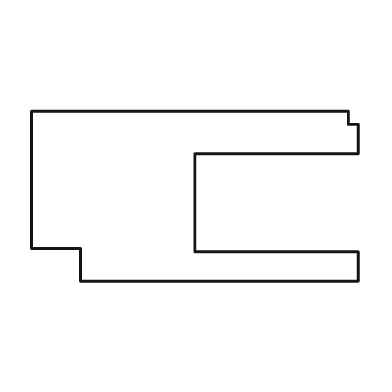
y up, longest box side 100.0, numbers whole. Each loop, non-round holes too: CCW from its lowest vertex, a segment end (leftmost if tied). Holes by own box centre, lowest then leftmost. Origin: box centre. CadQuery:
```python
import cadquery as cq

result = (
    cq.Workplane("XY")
    .moveTo(-35.0, -26.0)
    .lineTo(50.0, -26.0)
    .lineTo(50.0, -17.0)
    .lineTo(0.0, -17.0)
    .lineTo(0.0, 13.0)
    .lineTo(50.0, 13.0)
    .lineTo(50.0, 22.0)
    .lineTo(47.0, 22.0)
    .lineTo(47.0, 26.0)
    .lineTo(-50.0, 26.0)
    .lineTo(-50.0, -16.0)
    .lineTo(-35.0, -16.0)
    .close()
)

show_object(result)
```